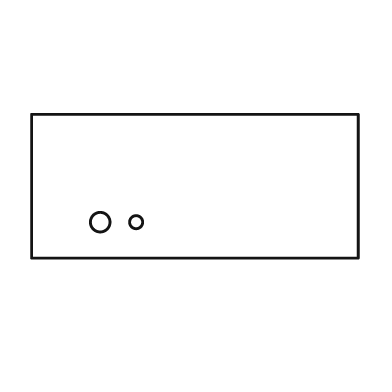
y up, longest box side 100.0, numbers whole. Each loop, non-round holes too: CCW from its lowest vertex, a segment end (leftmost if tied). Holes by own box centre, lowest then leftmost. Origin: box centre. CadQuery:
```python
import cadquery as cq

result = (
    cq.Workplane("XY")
    .moveTo(-50.0, -22.0)
    .lineTo(50.0, -22.0)
    .lineTo(50.0, 22.0)
    .lineTo(-50.0, 22.0)
    .close()
    .moveTo(-29.0, -11.0)
    .circle(3.0)
    .moveTo(-18.0, -11.0)
    .circle(2.0)
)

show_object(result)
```